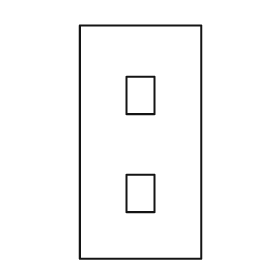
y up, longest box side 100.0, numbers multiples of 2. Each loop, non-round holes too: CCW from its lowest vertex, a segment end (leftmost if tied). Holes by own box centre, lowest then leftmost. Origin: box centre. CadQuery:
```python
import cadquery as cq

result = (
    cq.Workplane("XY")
    .moveTo(-26.0, -50.0)
    .lineTo(26.0, -50.0)
    .lineTo(26.0, 50.0)
    .lineTo(-26.0, 50.0)
    .close()
    .moveTo(-6.0, -30.0)
    .lineTo(6.0, -30.0)
    .lineTo(6.0, -14.0)
    .lineTo(-6.0, -14.0)
    .close()
    .moveTo(-6.0, 12.0)
    .lineTo(6.0, 12.0)
    .lineTo(6.0, 28.0)
    .lineTo(-6.0, 28.0)
    .close()
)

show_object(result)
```